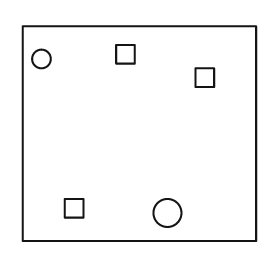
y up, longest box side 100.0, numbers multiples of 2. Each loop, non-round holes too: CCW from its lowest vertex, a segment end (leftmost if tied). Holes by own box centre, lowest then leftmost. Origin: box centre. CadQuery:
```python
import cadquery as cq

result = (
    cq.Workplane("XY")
    .moveTo(-50.0, -46.0)
    .lineTo(50.0, -46.0)
    .lineTo(50.0, 46.0)
    .lineTo(-50.0, 46.0)
    .close()
    .moveTo(12.0, -34.0)
    .circle(6.0)
    .moveTo(-32.0, -36.0)
    .lineTo(-24.0, -36.0)
    .lineTo(-24.0, -28.0)
    .lineTo(-32.0, -28.0)
    .close()
    .moveTo(24.0, 20.0)
    .lineTo(32.0, 20.0)
    .lineTo(32.0, 28.0)
    .lineTo(24.0, 28.0)
    .close()
    .moveTo(-42.0, 32.0)
    .circle(4.0)
    .moveTo(-10.0, 30.0)
    .lineTo(-2.0, 30.0)
    .lineTo(-2.0, 38.0)
    .lineTo(-10.0, 38.0)
    .close()
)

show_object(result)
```